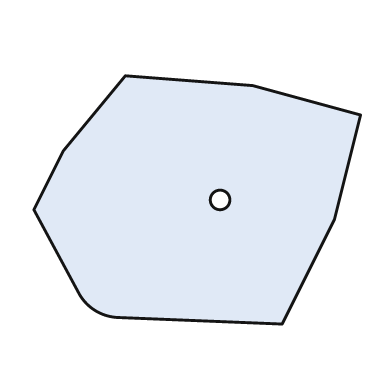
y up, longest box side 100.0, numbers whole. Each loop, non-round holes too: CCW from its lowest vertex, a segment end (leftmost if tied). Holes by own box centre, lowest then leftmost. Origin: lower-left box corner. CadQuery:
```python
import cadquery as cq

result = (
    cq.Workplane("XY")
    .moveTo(76.0, 0.0)
    .lineTo(92.0, 32.0)
    .lineTo(100.0, 64.0)
    .lineTo(67.0, 73.0)
    .lineTo(28.0, 76.0)
    .lineTo(9.0, 53.0)
    .lineTo(0.0, 35.0)
    .lineTo(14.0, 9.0)
    .threePointArc((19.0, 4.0), (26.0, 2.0))
    .close()
    .moveTo(57.0, 38.0)
    .circle(3.0)
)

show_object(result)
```